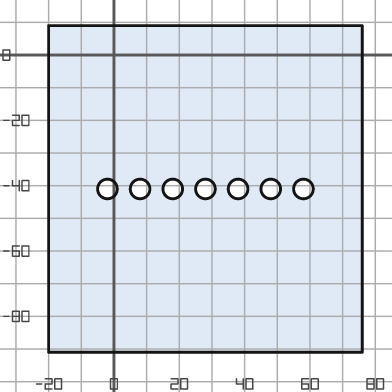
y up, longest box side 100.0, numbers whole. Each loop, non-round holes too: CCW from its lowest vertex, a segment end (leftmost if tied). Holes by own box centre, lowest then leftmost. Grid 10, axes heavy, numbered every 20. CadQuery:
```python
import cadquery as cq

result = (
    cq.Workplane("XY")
    .moveTo(-20.0, -91.0)
    .lineTo(76.0, -91.0)
    .lineTo(76.0, 9.0)
    .lineTo(-20.0, 9.0)
    .close()
    .moveTo(-2.0, -41.0)
    .circle(3.0)
    .moveTo(8.0, -41.0)
    .circle(3.0)
    .moveTo(18.0, -41.0)
    .circle(3.0)
    .moveTo(28.0, -41.0)
    .circle(3.0)
    .moveTo(38.0, -41.0)
    .circle(3.0)
    .moveTo(48.0, -41.0)
    .circle(3.0)
    .moveTo(58.0, -41.0)
    .circle(3.0)
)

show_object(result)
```